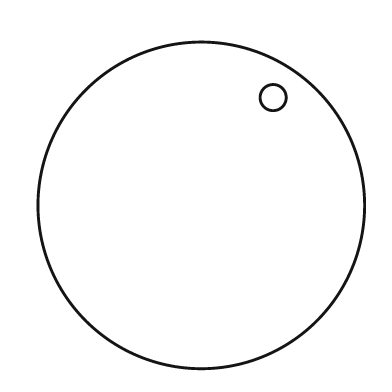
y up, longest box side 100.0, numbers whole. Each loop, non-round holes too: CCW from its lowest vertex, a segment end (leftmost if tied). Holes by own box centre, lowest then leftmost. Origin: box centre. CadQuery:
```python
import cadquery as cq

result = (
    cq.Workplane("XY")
    .moveTo(0.0, 0.0)
    .circle(50.0)
    .moveTo(22.0, 33.0)
    .circle(4.0)
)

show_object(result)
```